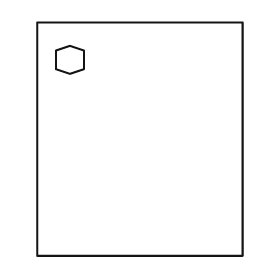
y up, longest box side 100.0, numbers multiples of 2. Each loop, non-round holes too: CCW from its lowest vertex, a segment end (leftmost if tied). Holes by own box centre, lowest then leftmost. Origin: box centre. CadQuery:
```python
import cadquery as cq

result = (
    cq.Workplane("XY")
    .moveTo(-44.0, -50.0)
    .lineTo(44.0, -50.0)
    .lineTo(44.0, 50.0)
    .lineTo(-44.0, 50.0)
    .close()
    .moveTo(-30.0, 28.0)
    .lineTo(-24.0, 30.0)
    .lineTo(-24.0, 38.0)
    .lineTo(-30.0, 40.0)
    .lineTo(-36.0, 38.0)
    .lineTo(-36.0, 30.0)
    .close()
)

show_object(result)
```